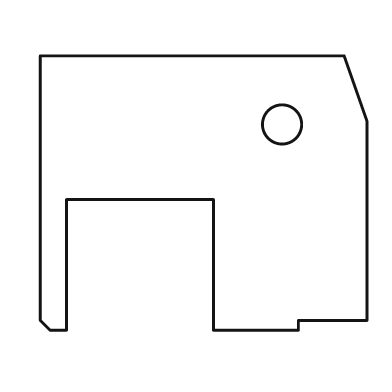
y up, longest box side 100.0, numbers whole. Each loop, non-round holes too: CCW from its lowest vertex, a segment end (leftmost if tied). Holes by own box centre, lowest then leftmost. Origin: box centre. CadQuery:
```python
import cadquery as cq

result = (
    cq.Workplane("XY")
    .moveTo(-47.0, -42.0)
    .lineTo(-42.0, -42.0)
    .lineTo(-42.0, -2.0)
    .lineTo(3.0, -2.0)
    .lineTo(3.0, -42.0)
    .lineTo(29.0, -42.0)
    .lineTo(29.0, -39.0)
    .lineTo(50.0, -39.0)
    .lineTo(50.0, 22.0)
    .lineTo(43.0, 42.0)
    .lineTo(-50.0, 42.0)
    .lineTo(-50.0, -39.0)
    .close()
    .moveTo(24.0, 21.0)
    .circle(6.0)
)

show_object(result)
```